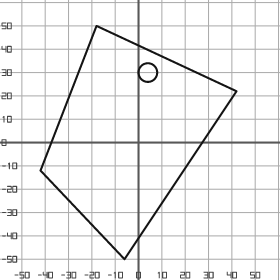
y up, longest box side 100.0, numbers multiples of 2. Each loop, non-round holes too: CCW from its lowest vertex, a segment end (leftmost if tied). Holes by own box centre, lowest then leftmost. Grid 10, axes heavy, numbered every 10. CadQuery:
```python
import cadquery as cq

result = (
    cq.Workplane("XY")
    .moveTo(-6.0, -50.0)
    .lineTo(42.0, 22.0)
    .lineTo(-18.0, 50.0)
    .lineTo(-42.0, -12.0)
    .close()
    .moveTo(4.0, 30.0)
    .circle(4.0)
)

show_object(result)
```